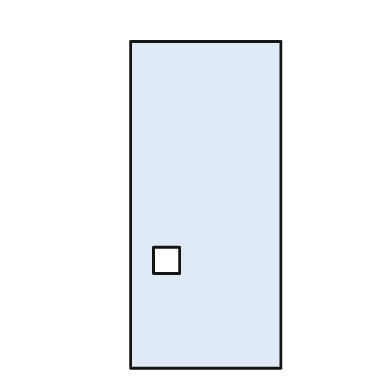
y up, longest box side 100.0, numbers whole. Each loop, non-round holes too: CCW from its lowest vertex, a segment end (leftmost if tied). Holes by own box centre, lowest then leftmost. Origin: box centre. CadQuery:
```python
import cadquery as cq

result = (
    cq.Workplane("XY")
    .moveTo(-23.0, -50.0)
    .lineTo(23.0, -50.0)
    .lineTo(23.0, 50.0)
    .lineTo(-23.0, 50.0)
    .close()
    .moveTo(-16.0, -21.0)
    .lineTo(-8.0, -21.0)
    .lineTo(-8.0, -13.0)
    .lineTo(-16.0, -13.0)
    .close()
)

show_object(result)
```